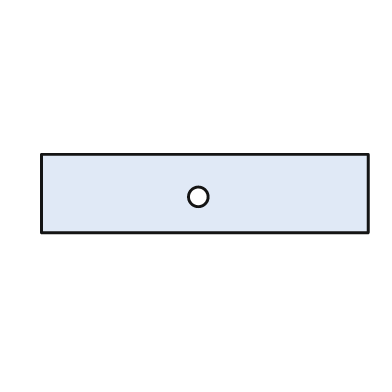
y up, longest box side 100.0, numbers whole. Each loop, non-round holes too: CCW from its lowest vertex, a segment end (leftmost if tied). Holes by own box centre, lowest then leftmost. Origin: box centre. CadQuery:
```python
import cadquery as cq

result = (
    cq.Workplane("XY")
    .moveTo(-50.0, -12.0)
    .lineTo(50.0, -12.0)
    .lineTo(50.0, 12.0)
    .lineTo(-50.0, 12.0)
    .close()
    .moveTo(-2.0, -1.0)
    .circle(3.0)
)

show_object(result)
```